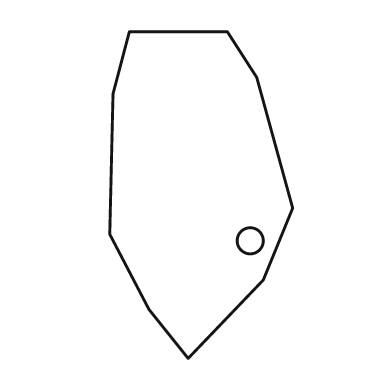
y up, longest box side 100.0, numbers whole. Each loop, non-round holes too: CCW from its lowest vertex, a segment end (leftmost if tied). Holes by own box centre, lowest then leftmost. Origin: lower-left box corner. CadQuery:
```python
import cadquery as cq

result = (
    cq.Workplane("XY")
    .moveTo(24.0, 0.0)
    .lineTo(47.0, 24.0)
    .lineTo(56.0, 46.0)
    .lineTo(45.0, 86.0)
    .lineTo(36.0, 100.0)
    .lineTo(6.0, 100.0)
    .lineTo(1.0, 81.0)
    .lineTo(0.0, 38.0)
    .lineTo(12.0, 15.0)
    .close()
    .moveTo(43.0, 36.0)
    .circle(4.0)
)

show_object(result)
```